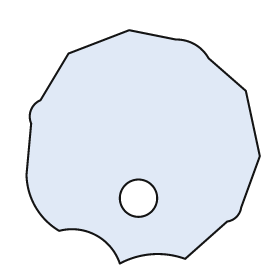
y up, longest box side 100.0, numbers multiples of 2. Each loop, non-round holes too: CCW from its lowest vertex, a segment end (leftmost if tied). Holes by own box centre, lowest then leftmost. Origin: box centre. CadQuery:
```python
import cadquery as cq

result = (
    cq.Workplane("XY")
    .moveTo(-10.0, -50.0)
    .threePointArc((4.0, -46.0), (18.0, -48.0))
    .lineTo(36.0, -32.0)
    .threePointArc((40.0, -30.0), (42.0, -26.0))
    .lineTo(50.0, -4.0)
    .lineTo(44.0, 24.0)
    .lineTo(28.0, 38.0)
    .threePointArc((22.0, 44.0), (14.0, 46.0))
    .lineTo(-6.0, 50.0)
    .lineTo(-32.0, 40.0)
    .lineTo(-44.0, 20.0)
    .threePointArc((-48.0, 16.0), (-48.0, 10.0))
    .lineTo(-50.0, -12.0)
    .threePointArc((-46.0, -26.0), (-36.0, -36.0))
    .threePointArc((-20.0, -38.0), (-10.0, -50.0))
    .close()
    .moveTo(-2.0, -22.0)
    .circle(8.0)
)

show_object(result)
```